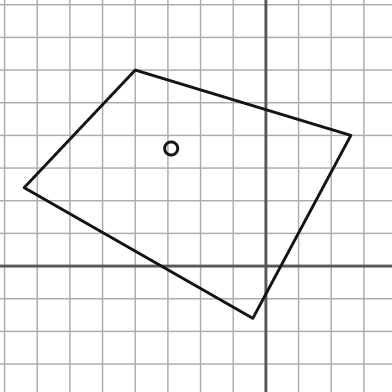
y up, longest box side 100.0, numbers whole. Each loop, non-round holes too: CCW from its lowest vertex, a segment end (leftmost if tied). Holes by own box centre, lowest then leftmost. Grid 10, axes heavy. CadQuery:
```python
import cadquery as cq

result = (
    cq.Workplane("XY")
    .moveTo(-4.0, -16.0)
    .lineTo(26.0, 40.0)
    .lineTo(-40.0, 60.0)
    .lineTo(-74.0, 24.0)
    .close()
    .moveTo(-29.0, 36.0)
    .circle(2.0)
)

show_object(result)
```